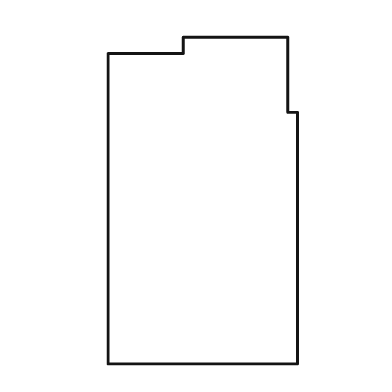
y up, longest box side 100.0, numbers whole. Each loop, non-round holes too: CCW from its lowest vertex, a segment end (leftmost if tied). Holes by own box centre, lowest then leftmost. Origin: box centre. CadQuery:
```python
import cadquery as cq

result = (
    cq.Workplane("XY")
    .moveTo(-29.0, -50.0)
    .lineTo(29.0, -50.0)
    .lineTo(29.0, 27.0)
    .lineTo(26.0, 27.0)
    .lineTo(26.0, 50.0)
    .lineTo(-6.0, 50.0)
    .lineTo(-6.0, 45.0)
    .lineTo(-29.0, 45.0)
    .close()
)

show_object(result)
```